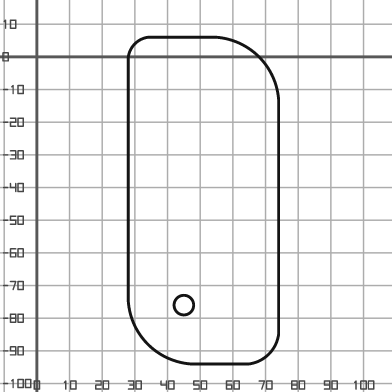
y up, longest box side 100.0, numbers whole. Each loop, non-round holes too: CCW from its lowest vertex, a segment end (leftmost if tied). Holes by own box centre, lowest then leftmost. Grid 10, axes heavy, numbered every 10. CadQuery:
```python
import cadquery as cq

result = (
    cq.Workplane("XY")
    .moveTo(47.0, -94.0)
    .lineTo(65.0, -94.0)
    .threePointArc((71.0, -91.0), (74.0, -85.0))
    .lineTo(74.0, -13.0)
    .threePointArc((68.0, 0.0), (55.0, 6.0))
    .lineTo(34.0, 6.0)
    .threePointArc((30.0, 4.0), (28.0, 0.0))
    .lineTo(28.0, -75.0)
    .threePointArc((34.0, -88.0), (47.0, -94.0))
    .close()
    .moveTo(45.0, -76.0)
    .circle(3.0)
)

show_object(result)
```